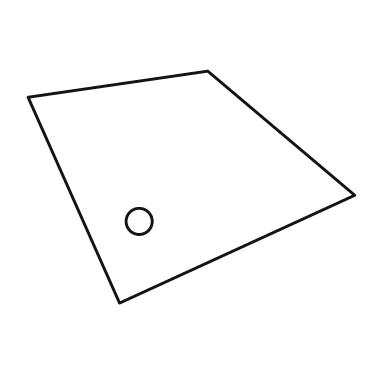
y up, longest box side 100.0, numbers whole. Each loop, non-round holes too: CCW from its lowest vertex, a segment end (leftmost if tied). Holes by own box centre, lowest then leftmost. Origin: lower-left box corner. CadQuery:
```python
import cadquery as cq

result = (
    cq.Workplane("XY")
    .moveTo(28.0, 0.0)
    .lineTo(100.0, 33.0)
    .lineTo(55.0, 71.0)
    .lineTo(0.0, 63.0)
    .close()
    .moveTo(34.0, 25.0)
    .circle(4.0)
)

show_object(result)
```